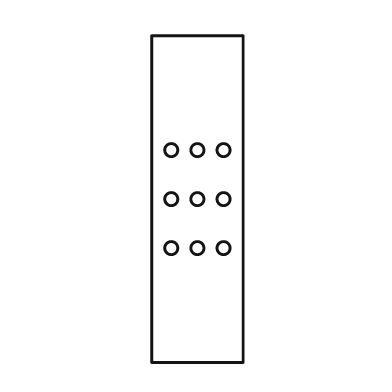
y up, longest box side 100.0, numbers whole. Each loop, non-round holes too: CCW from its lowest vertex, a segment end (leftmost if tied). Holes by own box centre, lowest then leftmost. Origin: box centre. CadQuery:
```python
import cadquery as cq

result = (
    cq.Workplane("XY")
    .moveTo(-14.0, -50.0)
    .lineTo(14.0, -50.0)
    .lineTo(14.0, 50.0)
    .lineTo(-14.0, 50.0)
    .close()
    .moveTo(-8.0, -15.0)
    .circle(2.0)
    .moveTo(0.0, -15.0)
    .circle(2.0)
    .moveTo(8.0, -15.0)
    .circle(2.0)
    .moveTo(-8.0, 0.0)
    .circle(2.0)
    .moveTo(0.0, 0.0)
    .circle(2.0)
    .moveTo(8.0, 0.0)
    .circle(2.0)
    .moveTo(-8.0, 15.0)
    .circle(2.0)
    .moveTo(0.0, 15.0)
    .circle(2.0)
    .moveTo(8.0, 15.0)
    .circle(2.0)
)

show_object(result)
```